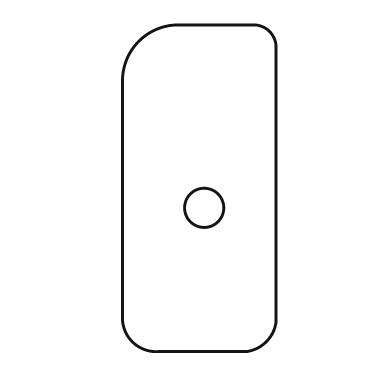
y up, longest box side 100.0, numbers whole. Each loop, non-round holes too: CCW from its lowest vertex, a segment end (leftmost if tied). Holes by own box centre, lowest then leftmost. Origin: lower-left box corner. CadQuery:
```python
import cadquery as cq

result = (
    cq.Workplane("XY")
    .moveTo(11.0, 0.0)
    .lineTo(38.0, 0.0)
    .threePointArc((44.0, 3.0), (47.0, 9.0))
    .lineTo(47.0, 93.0)
    .threePointArc((45.0, 98.0), (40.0, 100.0))
    .lineTo(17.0, 100.0)
    .threePointArc((5.0, 95.0), (0.0, 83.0))
    .lineTo(0.0, 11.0)
    .threePointArc((3.0, 3.0), (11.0, 0.0))
    .close()
    .moveTo(25.0, 44.0)
    .circle(6.0)
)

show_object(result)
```